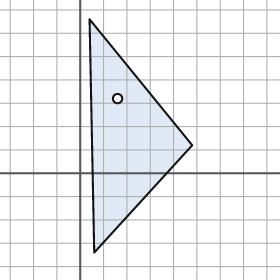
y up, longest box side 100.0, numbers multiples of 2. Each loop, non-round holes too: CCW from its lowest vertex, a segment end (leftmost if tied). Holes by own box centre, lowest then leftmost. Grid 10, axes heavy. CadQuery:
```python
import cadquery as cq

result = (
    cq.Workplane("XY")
    .moveTo(6.0, -34.0)
    .lineTo(48.0, 12.0)
    .lineTo(4.0, 66.0)
    .close()
    .moveTo(16.0, 32.0)
    .circle(2.0)
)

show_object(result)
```